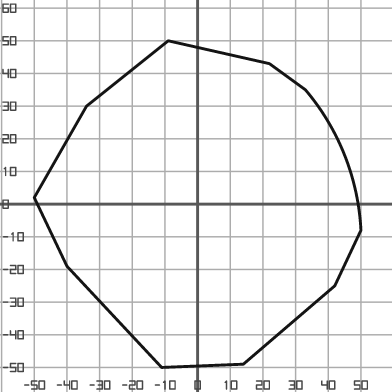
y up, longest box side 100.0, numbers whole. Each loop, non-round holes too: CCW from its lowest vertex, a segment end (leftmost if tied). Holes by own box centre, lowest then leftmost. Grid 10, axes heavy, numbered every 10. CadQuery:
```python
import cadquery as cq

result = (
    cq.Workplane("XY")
    .moveTo(-11.0, -50.0)
    .lineTo(14.0, -49.0)
    .lineTo(42.0, -25.0)
    .lineTo(50.0, -8.0)
    .threePointArc((45.0, 15.0), (33.0, 35.0))
    .lineTo(22.0, 43.0)
    .lineTo(-9.0, 50.0)
    .lineTo(-34.0, 30.0)
    .lineTo(-50.0, 2.0)
    .lineTo(-40.0, -19.0)
    .close()
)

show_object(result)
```